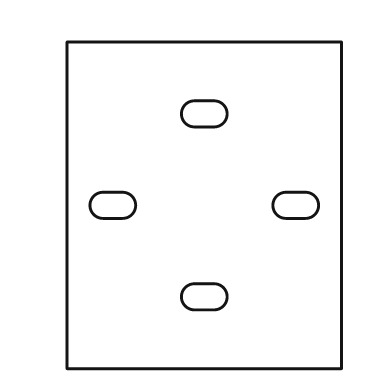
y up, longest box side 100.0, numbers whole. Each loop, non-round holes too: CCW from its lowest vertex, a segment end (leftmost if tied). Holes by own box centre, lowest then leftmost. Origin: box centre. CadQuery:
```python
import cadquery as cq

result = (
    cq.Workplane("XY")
    .moveTo(-42.0, -50.0)
    .lineTo(42.0, -50.0)
    .lineTo(42.0, 50.0)
    .lineTo(-42.0, 50.0)
    .close()
    .moveTo(-3.0, -32.0)
    .lineTo(3.0, -32.0)
    .threePointArc((7.0, -28.0), (3.0, -24.0))
    .lineTo(-3.0, -24.0)
    .threePointArc((-7.0, -28.0), (-3.0, -32.0))
    .close()
    .moveTo(-31.0, -4.0)
    .lineTo(-25.0, -4.0)
    .threePointArc((-21.0, 0.0), (-25.0, 4.0))
    .lineTo(-31.0, 4.0)
    .threePointArc((-35.0, 0.0), (-31.0, -4.0))
    .close()
    .moveTo(25.0, -4.0)
    .lineTo(31.0, -4.0)
    .threePointArc((35.0, 0.0), (31.0, 4.0))
    .lineTo(25.0, 4.0)
    .threePointArc((21.0, 0.0), (25.0, -4.0))
    .close()
    .moveTo(-3.0, 24.0)
    .lineTo(3.0, 24.0)
    .threePointArc((7.0, 28.0), (3.0, 32.0))
    .lineTo(-3.0, 32.0)
    .threePointArc((-7.0, 28.0), (-3.0, 24.0))
    .close()
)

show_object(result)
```